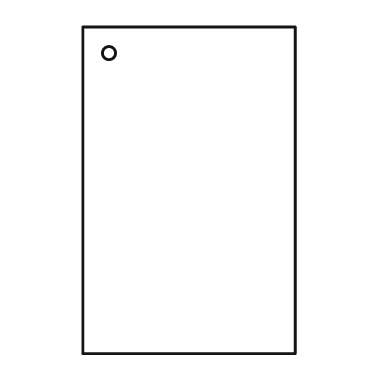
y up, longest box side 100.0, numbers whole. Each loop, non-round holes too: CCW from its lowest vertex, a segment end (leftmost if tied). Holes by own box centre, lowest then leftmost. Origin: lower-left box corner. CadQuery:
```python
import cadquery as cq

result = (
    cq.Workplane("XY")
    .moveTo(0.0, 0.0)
    .lineTo(65.0, 0.0)
    .lineTo(65.0, 100.0)
    .lineTo(0.0, 100.0)
    .close()
    .moveTo(8.0, 92.0)
    .circle(2.0)
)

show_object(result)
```